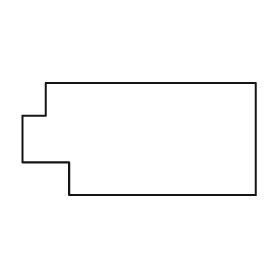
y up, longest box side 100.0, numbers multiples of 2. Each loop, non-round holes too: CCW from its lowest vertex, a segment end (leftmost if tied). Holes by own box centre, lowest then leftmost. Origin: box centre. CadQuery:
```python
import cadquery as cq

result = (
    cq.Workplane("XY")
    .moveTo(-30.0, -24.0)
    .lineTo(50.0, -24.0)
    .lineTo(50.0, 24.0)
    .lineTo(-40.0, 24.0)
    .lineTo(-40.0, 10.0)
    .lineTo(-50.0, 10.0)
    .lineTo(-50.0, -10.0)
    .lineTo(-30.0, -10.0)
    .close()
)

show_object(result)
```